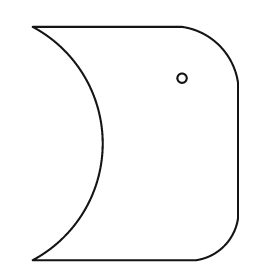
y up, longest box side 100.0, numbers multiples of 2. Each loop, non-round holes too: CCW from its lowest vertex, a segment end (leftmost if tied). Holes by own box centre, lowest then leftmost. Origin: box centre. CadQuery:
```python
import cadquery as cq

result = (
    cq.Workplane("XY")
    .moveTo(-44.0, -50.0)
    .lineTo(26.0, -50.0)
    .threePointArc((38.0, -44.0), (44.0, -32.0))
    .lineTo(44.0, 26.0)
    .threePointArc((36.0, 42.0), (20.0, 50.0))
    .lineTo(-44.0, 50.0)
    .threePointArc((-14.0, 0.0), (-44.0, -50.0))
    .close()
    .moveTo(20.0, 28.0)
    .circle(2.0)
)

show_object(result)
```